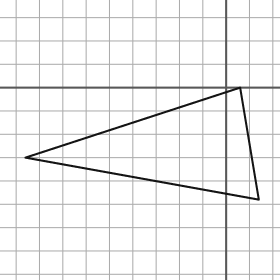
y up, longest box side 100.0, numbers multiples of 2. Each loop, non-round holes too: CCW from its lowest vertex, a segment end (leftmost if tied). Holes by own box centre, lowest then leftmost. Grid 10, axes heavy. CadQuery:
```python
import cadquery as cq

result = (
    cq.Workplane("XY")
    .moveTo(14.0, -48.0)
    .lineTo(6.0, 0.0)
    .lineTo(-86.0, -30.0)
    .close()
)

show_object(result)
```